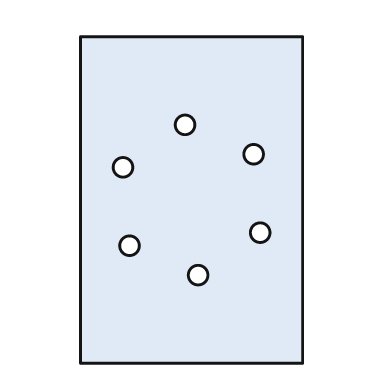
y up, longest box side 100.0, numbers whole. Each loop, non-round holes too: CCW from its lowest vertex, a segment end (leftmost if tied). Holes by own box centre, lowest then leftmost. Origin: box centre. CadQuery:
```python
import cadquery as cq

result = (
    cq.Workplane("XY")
    .moveTo(-34.0, -50.0)
    .lineTo(34.0, -50.0)
    .lineTo(34.0, 50.0)
    .lineTo(-34.0, 50.0)
    .close()
    .moveTo(2.0, -23.0)
    .circle(3.0)
    .moveTo(-19.0, -14.0)
    .circle(3.0)
    .moveTo(21.0, -10.0)
    .circle(3.0)
    .moveTo(-21.0, 10.0)
    .circle(3.0)
    .moveTo(19.0, 14.0)
    .circle(3.0)
    .moveTo(-2.0, 23.0)
    .circle(3.0)
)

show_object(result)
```